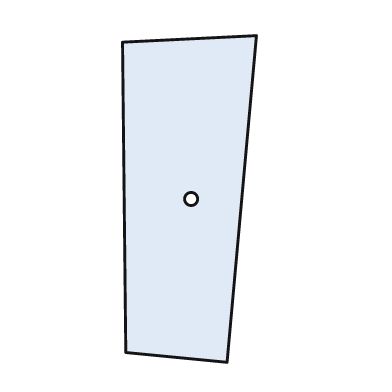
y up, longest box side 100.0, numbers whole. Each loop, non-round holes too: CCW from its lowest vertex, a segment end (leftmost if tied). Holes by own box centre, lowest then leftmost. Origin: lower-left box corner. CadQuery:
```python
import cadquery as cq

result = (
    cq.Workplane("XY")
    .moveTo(32.0, 0.0)
    .lineTo(41.0, 100.0)
    .lineTo(0.0, 98.0)
    .lineTo(1.0, 3.0)
    .close()
    .moveTo(21.0, 50.0)
    .circle(2.0)
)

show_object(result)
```